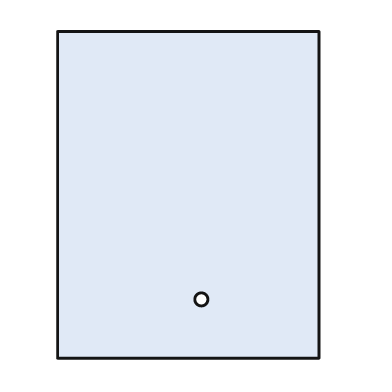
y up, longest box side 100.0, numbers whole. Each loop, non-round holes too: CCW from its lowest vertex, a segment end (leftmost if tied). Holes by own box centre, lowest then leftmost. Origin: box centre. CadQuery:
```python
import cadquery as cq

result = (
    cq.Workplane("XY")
    .moveTo(-40.0, -50.0)
    .lineTo(40.0, -50.0)
    .lineTo(40.0, 50.0)
    .lineTo(-40.0, 50.0)
    .close()
    .moveTo(4.0, -32.0)
    .circle(2.0)
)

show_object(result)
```